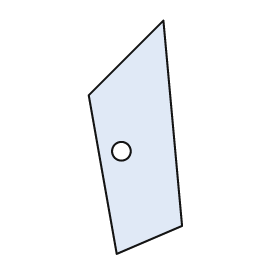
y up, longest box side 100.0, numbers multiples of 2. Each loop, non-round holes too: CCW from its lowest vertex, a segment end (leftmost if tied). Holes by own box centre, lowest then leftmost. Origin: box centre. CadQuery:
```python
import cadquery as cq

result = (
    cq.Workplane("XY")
    .moveTo(-8.0, -50.0)
    .lineTo(20.0, -38.0)
    .lineTo(12.0, 50.0)
    .lineTo(-20.0, 18.0)
    .close()
    .moveTo(-6.0, -6.0)
    .circle(4.0)
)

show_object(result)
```